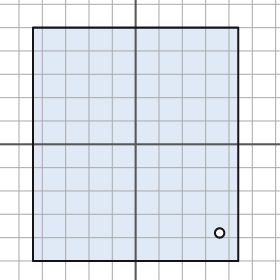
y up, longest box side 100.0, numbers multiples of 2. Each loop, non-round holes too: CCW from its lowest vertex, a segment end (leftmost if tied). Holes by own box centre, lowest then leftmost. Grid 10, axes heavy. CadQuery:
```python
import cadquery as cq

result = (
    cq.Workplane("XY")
    .moveTo(-44.0, -50.0)
    .lineTo(44.0, -50.0)
    .lineTo(44.0, 50.0)
    .lineTo(-44.0, 50.0)
    .close()
    .moveTo(36.0, -38.0)
    .circle(2.0)
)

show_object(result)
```